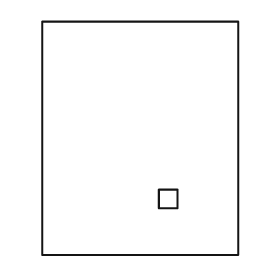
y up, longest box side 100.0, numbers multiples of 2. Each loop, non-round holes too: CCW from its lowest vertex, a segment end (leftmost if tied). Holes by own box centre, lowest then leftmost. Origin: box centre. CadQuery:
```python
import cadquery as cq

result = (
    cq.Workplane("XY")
    .moveTo(-42.0, -50.0)
    .lineTo(42.0, -50.0)
    .lineTo(42.0, 50.0)
    .lineTo(-42.0, 50.0)
    .close()
    .moveTo(8.0, -30.0)
    .lineTo(16.0, -30.0)
    .lineTo(16.0, -22.0)
    .lineTo(8.0, -22.0)
    .close()
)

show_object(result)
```